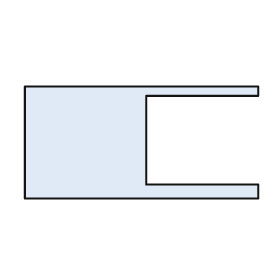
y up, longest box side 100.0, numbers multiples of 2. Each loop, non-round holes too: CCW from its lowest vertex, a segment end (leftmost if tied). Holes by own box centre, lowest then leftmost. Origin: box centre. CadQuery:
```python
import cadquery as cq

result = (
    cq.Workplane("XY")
    .moveTo(-50.0, -24.0)
    .lineTo(50.0, -24.0)
    .lineTo(50.0, -18.0)
    .lineTo(2.0, -18.0)
    .lineTo(2.0, 20.0)
    .lineTo(50.0, 20.0)
    .lineTo(50.0, 24.0)
    .lineTo(-50.0, 24.0)
    .close()
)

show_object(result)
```